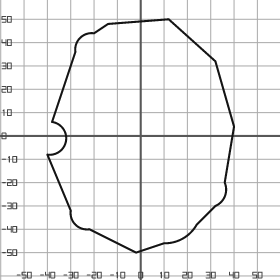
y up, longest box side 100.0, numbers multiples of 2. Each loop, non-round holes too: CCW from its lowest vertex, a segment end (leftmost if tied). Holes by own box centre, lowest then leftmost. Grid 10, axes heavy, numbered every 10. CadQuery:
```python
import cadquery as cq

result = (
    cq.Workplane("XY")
    .moveTo(-2.0, -50.0)
    .lineTo(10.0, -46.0)
    .threePointArc((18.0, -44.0), (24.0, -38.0))
    .lineTo(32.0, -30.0)
    .threePointArc((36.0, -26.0), (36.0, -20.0))
    .lineTo(40.0, 4.0)
    .lineTo(32.0, 32.0)
    .lineTo(12.0, 50.0)
    .lineTo(-14.0, 48.0)
    .lineTo(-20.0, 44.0)
    .threePointArc((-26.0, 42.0), (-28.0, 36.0))
    .lineTo(-38.0, 6.0)
    .threePointArc((-32.0, -2.0), (-40.0, -8.0))
    .lineTo(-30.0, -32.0)
    .threePointArc((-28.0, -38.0), (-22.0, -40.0))
    .close()
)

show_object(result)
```